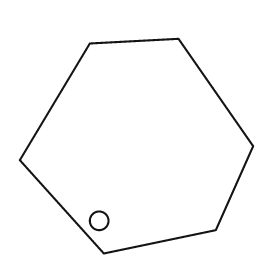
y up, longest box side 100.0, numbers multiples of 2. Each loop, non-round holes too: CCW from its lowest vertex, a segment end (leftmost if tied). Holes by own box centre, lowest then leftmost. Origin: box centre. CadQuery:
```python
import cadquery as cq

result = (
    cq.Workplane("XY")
    .moveTo(-14.0, -46.0)
    .lineTo(34.0, -36.0)
    .lineTo(50.0, 0.0)
    .lineTo(18.0, 46.0)
    .lineTo(-20.0, 44.0)
    .lineTo(-50.0, -6.0)
    .close()
    .moveTo(-16.0, -32.0)
    .circle(4.0)
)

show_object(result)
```